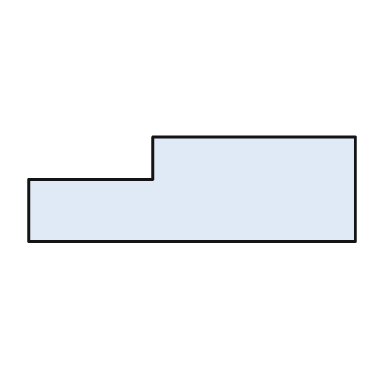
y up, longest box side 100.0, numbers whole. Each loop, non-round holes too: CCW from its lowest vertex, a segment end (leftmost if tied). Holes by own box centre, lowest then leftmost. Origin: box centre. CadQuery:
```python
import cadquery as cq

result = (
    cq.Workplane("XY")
    .moveTo(-50.0, -16.0)
    .lineTo(50.0, -16.0)
    .lineTo(50.0, 16.0)
    .lineTo(-12.0, 16.0)
    .lineTo(-12.0, 3.0)
    .lineTo(-50.0, 3.0)
    .close()
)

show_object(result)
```